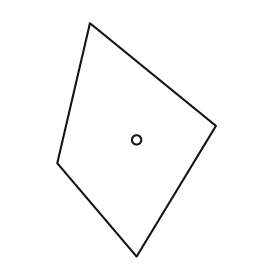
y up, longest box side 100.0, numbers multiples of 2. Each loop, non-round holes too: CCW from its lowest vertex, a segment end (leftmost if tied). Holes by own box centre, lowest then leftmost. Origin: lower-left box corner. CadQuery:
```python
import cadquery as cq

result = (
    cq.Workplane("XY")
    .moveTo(34.0, 0.0)
    .lineTo(68.0, 56.0)
    .lineTo(14.0, 100.0)
    .lineTo(0.0, 40.0)
    .close()
    .moveTo(34.0, 50.0)
    .circle(2.0)
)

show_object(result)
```